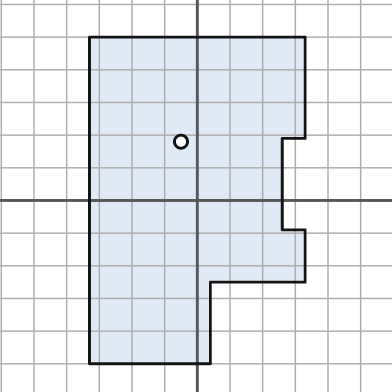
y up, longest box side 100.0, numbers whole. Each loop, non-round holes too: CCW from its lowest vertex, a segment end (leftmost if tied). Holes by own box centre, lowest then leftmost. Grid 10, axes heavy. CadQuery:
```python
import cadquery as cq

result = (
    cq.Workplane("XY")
    .moveTo(-33.0, -50.0)
    .lineTo(4.0, -50.0)
    .lineTo(4.0, -25.0)
    .lineTo(33.0, -25.0)
    .lineTo(33.0, -9.0)
    .lineTo(26.0, -9.0)
    .lineTo(26.0, 19.0)
    .lineTo(33.0, 19.0)
    .lineTo(33.0, 50.0)
    .lineTo(-33.0, 50.0)
    .close()
    .moveTo(-5.0, 18.0)
    .circle(2.0)
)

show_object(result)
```